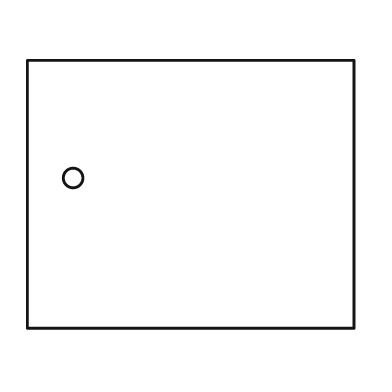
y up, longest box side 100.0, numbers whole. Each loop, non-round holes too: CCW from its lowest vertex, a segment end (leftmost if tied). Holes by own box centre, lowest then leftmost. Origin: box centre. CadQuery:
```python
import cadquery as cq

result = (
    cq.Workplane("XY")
    .moveTo(-50.0, -41.0)
    .lineTo(50.0, -41.0)
    .lineTo(50.0, 41.0)
    .lineTo(-50.0, 41.0)
    .close()
    .moveTo(-36.0, 5.0)
    .circle(3.0)
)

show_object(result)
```